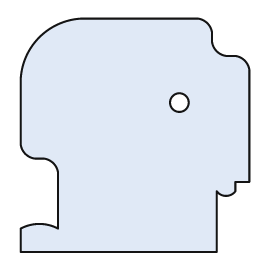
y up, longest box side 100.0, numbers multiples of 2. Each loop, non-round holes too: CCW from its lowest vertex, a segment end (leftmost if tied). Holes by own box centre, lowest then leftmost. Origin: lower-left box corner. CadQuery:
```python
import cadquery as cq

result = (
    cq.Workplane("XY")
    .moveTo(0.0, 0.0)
    .lineTo(84.0, 0.0)
    .lineTo(84.0, 26.0)
    .threePointArc((88.0, 24.0), (92.0, 26.0))
    .lineTo(92.0, 30.0)
    .lineTo(98.0, 30.0)
    .lineTo(98.0, 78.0)
    .threePointArc((96.0, 82.0), (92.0, 84.0))
    .lineTo(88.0, 84.0)
    .threePointArc((84.0, 86.0), (82.0, 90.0))
    .lineTo(82.0, 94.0)
    .threePointArc((80.0, 98.0), (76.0, 100.0))
    .lineTo(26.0, 100.0)
    .threePointArc((8.0, 92.0), (0.0, 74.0))
    .lineTo(0.0, 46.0)
    .threePointArc((2.0, 42.0), (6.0, 40.0))
    .lineTo(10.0, 40.0)
    .threePointArc((14.0, 38.0), (16.0, 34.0))
    .lineTo(16.0, 10.0)
    .threePointArc((8.0, 12.0), (0.0, 10.0))
    .close()
    .moveTo(68.0, 64.0)
    .circle(4.0)
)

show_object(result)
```